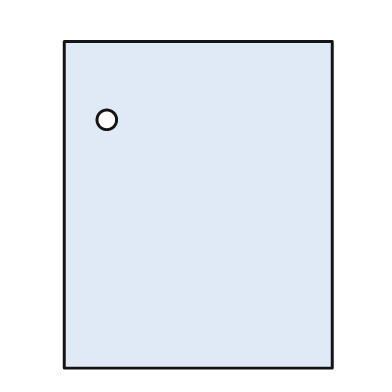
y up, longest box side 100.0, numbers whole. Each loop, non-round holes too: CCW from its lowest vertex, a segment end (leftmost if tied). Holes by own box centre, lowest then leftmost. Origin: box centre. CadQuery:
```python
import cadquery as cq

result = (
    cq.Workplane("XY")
    .moveTo(-41.0, -50.0)
    .lineTo(41.0, -50.0)
    .lineTo(41.0, 50.0)
    .lineTo(-41.0, 50.0)
    .close()
    .moveTo(-28.0, 26.0)
    .circle(3.0)
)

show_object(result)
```